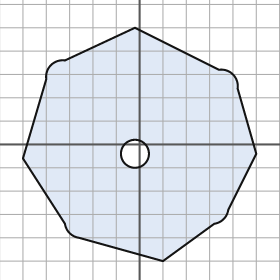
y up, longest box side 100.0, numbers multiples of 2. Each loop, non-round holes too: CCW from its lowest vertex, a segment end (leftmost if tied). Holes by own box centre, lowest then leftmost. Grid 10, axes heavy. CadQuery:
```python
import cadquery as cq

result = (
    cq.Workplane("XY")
    .moveTo(10.0, -50.0)
    .lineTo(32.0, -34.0)
    .threePointArc((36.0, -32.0), (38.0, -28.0))
    .lineTo(50.0, -4.0)
    .lineTo(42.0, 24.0)
    .threePointArc((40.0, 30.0), (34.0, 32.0))
    .lineTo(-2.0, 50.0)
    .lineTo(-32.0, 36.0)
    .threePointArc((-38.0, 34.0), (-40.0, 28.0))
    .lineTo(-50.0, -6.0)
    .lineTo(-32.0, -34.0)
    .threePointArc((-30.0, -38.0), (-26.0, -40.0))
    .close()
    .moveTo(-2.0, -4.0)
    .circle(6.0)
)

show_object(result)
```